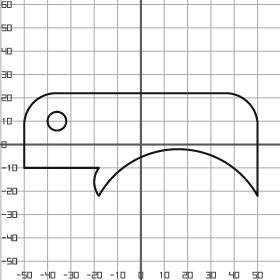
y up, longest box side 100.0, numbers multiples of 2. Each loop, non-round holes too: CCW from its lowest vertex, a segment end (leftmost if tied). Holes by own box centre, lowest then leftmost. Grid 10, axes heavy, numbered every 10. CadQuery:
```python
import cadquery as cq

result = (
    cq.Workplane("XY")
    .moveTo(-18.0, -22.0)
    .threePointArc((16.0, -2.0), (50.0, -22.0))
    .lineTo(50.0, 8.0)
    .threePointArc((46.0, 18.0), (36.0, 22.0))
    .lineTo(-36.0, 22.0)
    .threePointArc((-46.0, 18.0), (-50.0, 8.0))
    .lineTo(-50.0, -10.0)
    .lineTo(-18.0, -10.0)
    .threePointArc((-20.0, -16.0), (-18.0, -22.0))
    .close()
    .moveTo(-36.0, 10.0)
    .circle(4.0)
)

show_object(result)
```